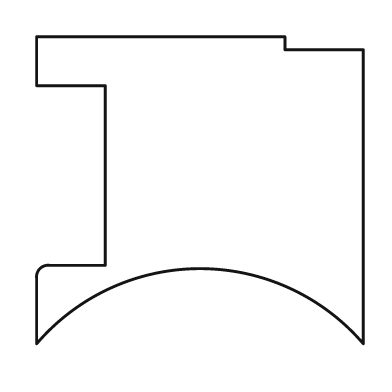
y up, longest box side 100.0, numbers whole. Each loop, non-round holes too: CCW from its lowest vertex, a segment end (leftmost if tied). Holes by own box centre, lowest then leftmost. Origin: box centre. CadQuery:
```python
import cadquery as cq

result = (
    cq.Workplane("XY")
    .moveTo(-50.0, -47.0)
    .threePointArc((0.0, -24.0), (50.0, -47.0))
    .lineTo(50.0, 43.0)
    .lineTo(26.0, 43.0)
    .lineTo(26.0, 47.0)
    .lineTo(-50.0, 47.0)
    .lineTo(-50.0, 32.0)
    .lineTo(-29.0, 32.0)
    .lineTo(-29.0, -23.0)
    .lineTo(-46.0, -23.0)
    .threePointArc((-49.0, -24.0), (-50.0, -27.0))
    .close()
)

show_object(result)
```